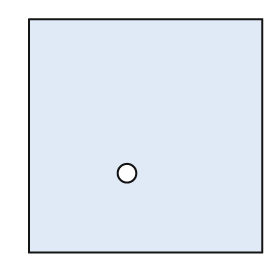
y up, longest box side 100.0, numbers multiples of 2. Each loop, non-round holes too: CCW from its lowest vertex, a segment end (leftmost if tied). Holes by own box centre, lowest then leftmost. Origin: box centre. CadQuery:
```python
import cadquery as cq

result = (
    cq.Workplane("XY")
    .moveTo(-50.0, -50.0)
    .lineTo(50.0, -50.0)
    .lineTo(50.0, 50.0)
    .lineTo(-50.0, 50.0)
    .close()
    .moveTo(-8.0, -16.0)
    .circle(4.0)
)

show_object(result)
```